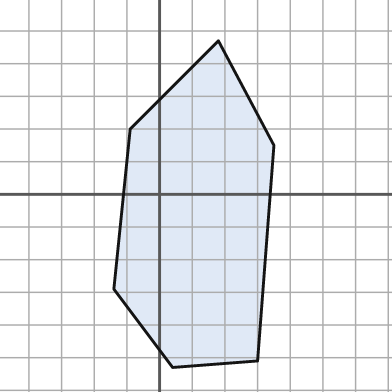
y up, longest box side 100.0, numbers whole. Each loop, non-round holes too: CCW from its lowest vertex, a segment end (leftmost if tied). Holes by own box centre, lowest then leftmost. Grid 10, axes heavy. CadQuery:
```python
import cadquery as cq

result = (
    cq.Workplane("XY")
    .moveTo(4.0, -53.0)
    .lineTo(30.0, -51.0)
    .lineTo(35.0, 15.0)
    .lineTo(18.0, 47.0)
    .lineTo(-9.0, 20.0)
    .lineTo(-14.0, -29.0)
    .close()
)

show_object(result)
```